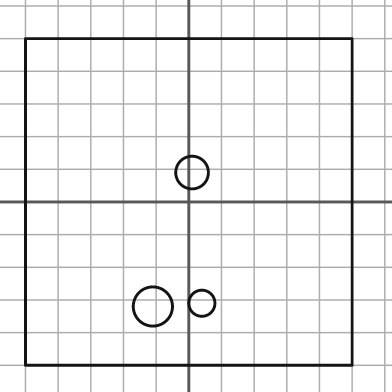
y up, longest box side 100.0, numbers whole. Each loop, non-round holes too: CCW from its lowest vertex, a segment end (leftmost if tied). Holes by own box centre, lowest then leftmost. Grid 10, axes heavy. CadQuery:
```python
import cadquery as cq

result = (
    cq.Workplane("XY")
    .moveTo(-50.0, -50.0)
    .lineTo(50.0, -50.0)
    .lineTo(50.0, 50.0)
    .lineTo(-50.0, 50.0)
    .close()
    .moveTo(-11.0, -32.0)
    .circle(6.0)
    .moveTo(4.0, -31.0)
    .circle(4.0)
    .moveTo(1.0, 9.0)
    .circle(5.0)
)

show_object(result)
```